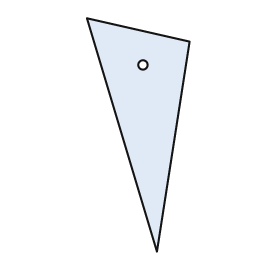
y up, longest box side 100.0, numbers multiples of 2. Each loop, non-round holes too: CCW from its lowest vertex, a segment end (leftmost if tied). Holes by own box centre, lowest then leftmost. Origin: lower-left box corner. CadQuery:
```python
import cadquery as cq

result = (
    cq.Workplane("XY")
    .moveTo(30.0, 0.0)
    .lineTo(44.0, 90.0)
    .lineTo(0.0, 100.0)
    .close()
    .moveTo(24.0, 80.0)
    .circle(2.0)
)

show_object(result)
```